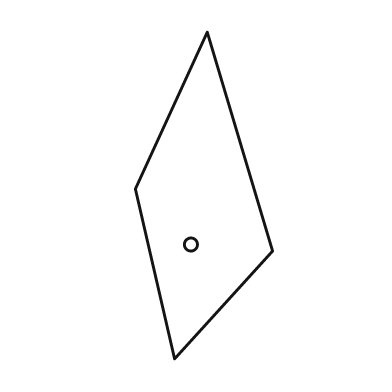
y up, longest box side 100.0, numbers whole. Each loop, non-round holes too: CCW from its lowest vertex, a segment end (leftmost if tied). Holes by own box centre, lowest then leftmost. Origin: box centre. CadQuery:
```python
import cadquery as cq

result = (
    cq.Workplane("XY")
    .moveTo(-9.0, -50.0)
    .lineTo(21.0, -17.0)
    .lineTo(1.0, 50.0)
    .lineTo(-21.0, 2.0)
    .close()
    .moveTo(-4.0, -15.0)
    .circle(2.0)
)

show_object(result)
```